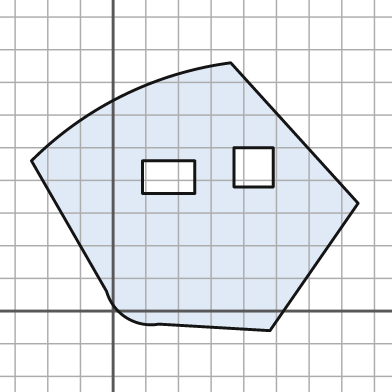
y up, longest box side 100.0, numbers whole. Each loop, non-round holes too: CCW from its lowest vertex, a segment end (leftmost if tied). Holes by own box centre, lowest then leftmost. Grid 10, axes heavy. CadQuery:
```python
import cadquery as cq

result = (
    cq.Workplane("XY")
    .moveTo(48.0, -6.0)
    .lineTo(75.0, 33.0)
    .lineTo(36.0, 76.0)
    .threePointArc((3.0, 66.0), (-25.0, 46.0))
    .lineTo(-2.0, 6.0)
    .threePointArc((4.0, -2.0), (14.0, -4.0))
    .close()
    .moveTo(9.0, 36.0)
    .lineTo(25.0, 36.0)
    .lineTo(25.0, 46.0)
    .lineTo(9.0, 46.0)
    .close()
    .moveTo(37.0, 38.0)
    .lineTo(49.0, 38.0)
    .lineTo(49.0, 50.0)
    .lineTo(37.0, 50.0)
    .close()
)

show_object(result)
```